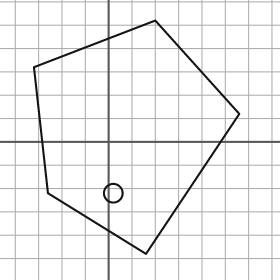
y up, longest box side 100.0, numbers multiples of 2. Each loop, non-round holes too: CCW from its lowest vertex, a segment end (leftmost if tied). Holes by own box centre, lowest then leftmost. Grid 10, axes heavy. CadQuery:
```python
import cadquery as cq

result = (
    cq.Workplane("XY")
    .moveTo(16.0, -48.0)
    .lineTo(56.0, 12.0)
    .lineTo(20.0, 52.0)
    .lineTo(-32.0, 32.0)
    .lineTo(-26.0, -22.0)
    .close()
    .moveTo(2.0, -22.0)
    .circle(4.0)
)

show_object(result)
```